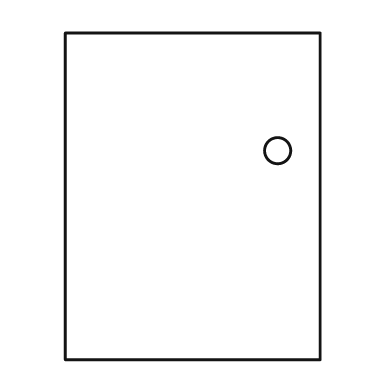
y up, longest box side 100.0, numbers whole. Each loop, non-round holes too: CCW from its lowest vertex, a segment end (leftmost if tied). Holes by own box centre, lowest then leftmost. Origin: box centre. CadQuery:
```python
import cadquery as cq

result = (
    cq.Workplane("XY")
    .moveTo(-39.0, -50.0)
    .lineTo(39.0, -50.0)
    .lineTo(39.0, 50.0)
    .lineTo(-39.0, 50.0)
    .close()
    .moveTo(26.0, 14.0)
    .circle(4.0)
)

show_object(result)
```